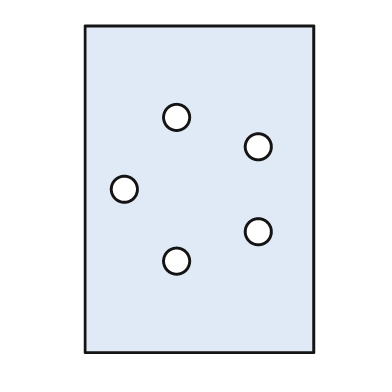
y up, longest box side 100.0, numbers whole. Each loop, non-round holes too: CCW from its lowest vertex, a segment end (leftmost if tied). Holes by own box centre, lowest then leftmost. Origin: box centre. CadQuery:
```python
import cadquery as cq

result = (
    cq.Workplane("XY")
    .moveTo(-35.0, -50.0)
    .lineTo(35.0, -50.0)
    .lineTo(35.0, 50.0)
    .lineTo(-35.0, 50.0)
    .close()
    .moveTo(-7.0, -22.0)
    .circle(4.0)
    .moveTo(18.0, -13.0)
    .circle(4.0)
    .moveTo(-23.0, 0.0)
    .circle(4.0)
    .moveTo(18.0, 13.0)
    .circle(4.0)
    .moveTo(-7.0, 22.0)
    .circle(4.0)
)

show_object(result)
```